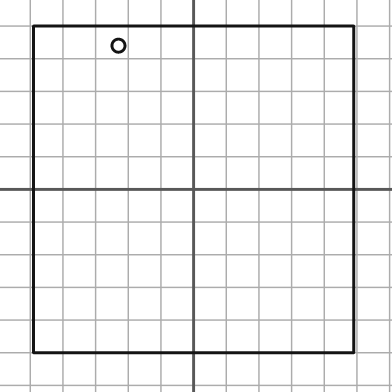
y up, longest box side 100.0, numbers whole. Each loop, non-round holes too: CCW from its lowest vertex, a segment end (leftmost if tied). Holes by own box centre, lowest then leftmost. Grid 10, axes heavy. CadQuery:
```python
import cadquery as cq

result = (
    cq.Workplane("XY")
    .moveTo(-49.0, -50.0)
    .lineTo(49.0, -50.0)
    .lineTo(49.0, 50.0)
    .lineTo(-49.0, 50.0)
    .close()
    .moveTo(-23.0, 44.0)
    .circle(2.0)
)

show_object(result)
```